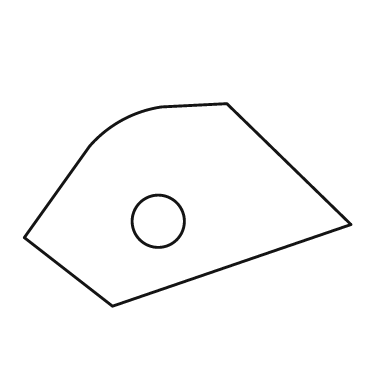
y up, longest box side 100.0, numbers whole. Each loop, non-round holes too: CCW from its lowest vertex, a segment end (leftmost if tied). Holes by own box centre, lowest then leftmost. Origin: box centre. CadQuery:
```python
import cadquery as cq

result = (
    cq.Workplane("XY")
    .moveTo(-23.0, -31.0)
    .lineTo(50.0, -6.0)
    .lineTo(12.0, 31.0)
    .lineTo(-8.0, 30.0)
    .threePointArc((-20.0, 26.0), (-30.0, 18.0))
    .lineTo(-50.0, -10.0)
    .close()
    .moveTo(-9.0, -5.0)
    .circle(8.0)
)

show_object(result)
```